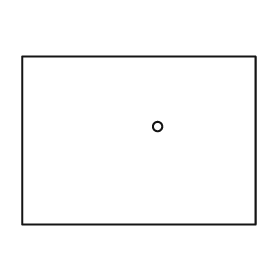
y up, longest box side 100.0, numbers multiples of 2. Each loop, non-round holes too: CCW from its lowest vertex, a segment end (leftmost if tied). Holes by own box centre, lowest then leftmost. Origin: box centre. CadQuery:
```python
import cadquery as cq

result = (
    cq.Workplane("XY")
    .moveTo(-50.0, -36.0)
    .lineTo(50.0, -36.0)
    .lineTo(50.0, 36.0)
    .lineTo(-50.0, 36.0)
    .close()
    .moveTo(8.0, 6.0)
    .circle(2.0)
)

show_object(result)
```